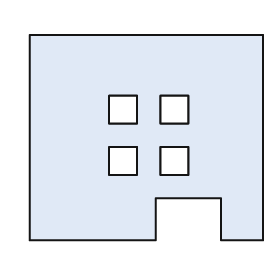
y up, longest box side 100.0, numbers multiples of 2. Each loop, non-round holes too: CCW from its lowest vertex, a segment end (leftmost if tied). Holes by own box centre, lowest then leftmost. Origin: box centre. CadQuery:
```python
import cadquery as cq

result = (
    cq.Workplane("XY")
    .moveTo(-50.0, -44.0)
    .lineTo(4.0, -44.0)
    .lineTo(4.0, -26.0)
    .lineTo(32.0, -26.0)
    .lineTo(32.0, -44.0)
    .lineTo(50.0, -44.0)
    .lineTo(50.0, 44.0)
    .lineTo(-50.0, 44.0)
    .close()
    .moveTo(-16.0, -16.0)
    .lineTo(-4.0, -16.0)
    .lineTo(-4.0, -4.0)
    .lineTo(-16.0, -4.0)
    .close()
    .moveTo(6.0, -16.0)
    .lineTo(18.0, -16.0)
    .lineTo(18.0, -4.0)
    .lineTo(6.0, -4.0)
    .close()
    .moveTo(-16.0, 6.0)
    .lineTo(-4.0, 6.0)
    .lineTo(-4.0, 18.0)
    .lineTo(-16.0, 18.0)
    .close()
    .moveTo(6.0, 6.0)
    .lineTo(18.0, 6.0)
    .lineTo(18.0, 18.0)
    .lineTo(6.0, 18.0)
    .close()
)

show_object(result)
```